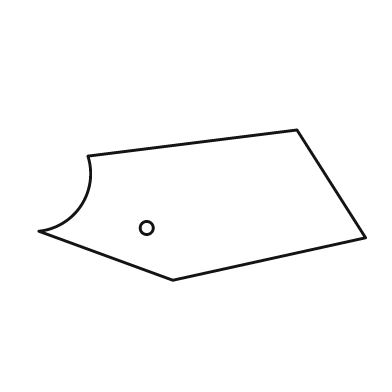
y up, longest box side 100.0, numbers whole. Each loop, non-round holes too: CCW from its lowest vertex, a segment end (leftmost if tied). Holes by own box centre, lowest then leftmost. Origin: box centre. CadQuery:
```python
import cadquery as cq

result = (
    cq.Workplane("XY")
    .moveTo(-9.0, -23.0)
    .lineTo(50.0, -10.0)
    .lineTo(29.0, 23.0)
    .lineTo(-35.0, 15.0)
    .threePointArc((-37.0, 0.0), (-50.0, -8.0))
    .close()
    .moveTo(-17.0, -7.0)
    .circle(2.0)
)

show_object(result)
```